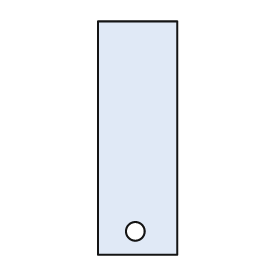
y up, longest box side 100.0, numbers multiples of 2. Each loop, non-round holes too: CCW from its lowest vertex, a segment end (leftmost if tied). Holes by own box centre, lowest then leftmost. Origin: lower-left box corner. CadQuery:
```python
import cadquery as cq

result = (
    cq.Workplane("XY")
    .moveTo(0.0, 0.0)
    .lineTo(34.0, 0.0)
    .lineTo(34.0, 100.0)
    .lineTo(0.0, 100.0)
    .close()
    .moveTo(16.0, 10.0)
    .circle(4.0)
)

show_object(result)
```